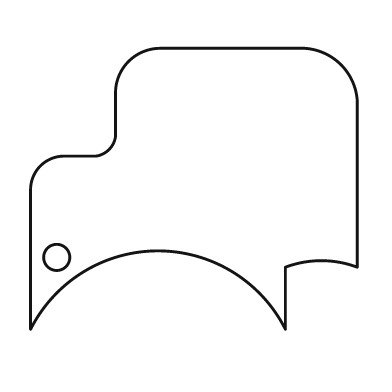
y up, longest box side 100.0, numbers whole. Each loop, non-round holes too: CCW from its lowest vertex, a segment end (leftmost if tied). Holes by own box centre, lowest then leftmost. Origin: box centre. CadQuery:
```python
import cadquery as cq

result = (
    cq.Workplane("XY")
    .moveTo(-50.0, -43.0)
    .threePointArc((-11.0, -19.0), (28.0, -43.0))
    .lineTo(28.0, -24.0)
    .threePointArc((39.0, -22.0), (50.0, -24.0))
    .lineTo(50.0, 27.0)
    .threePointArc((45.0, 38.0), (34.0, 43.0))
    .lineTo(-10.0, 43.0)
    .threePointArc((-20.0, 39.0), (-24.0, 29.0))
    .lineTo(-24.0, 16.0)
    .threePointArc((-26.0, 12.0), (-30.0, 10.0))
    .lineTo(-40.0, 10.0)
    .threePointArc((-47.0, 7.0), (-50.0, 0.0))
    .close()
    .moveTo(-42.0, -21.0)
    .circle(4.0)
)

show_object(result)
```